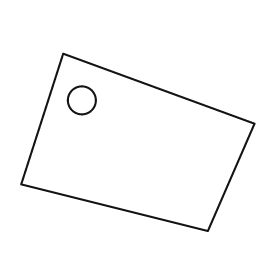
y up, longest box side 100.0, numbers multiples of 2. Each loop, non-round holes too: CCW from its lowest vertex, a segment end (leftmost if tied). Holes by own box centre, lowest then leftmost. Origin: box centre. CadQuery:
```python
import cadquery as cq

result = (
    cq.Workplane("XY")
    .moveTo(30.0, -38.0)
    .lineTo(50.0, 8.0)
    .lineTo(-32.0, 38.0)
    .lineTo(-50.0, -18.0)
    .close()
    .moveTo(-24.0, 18.0)
    .circle(6.0)
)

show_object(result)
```